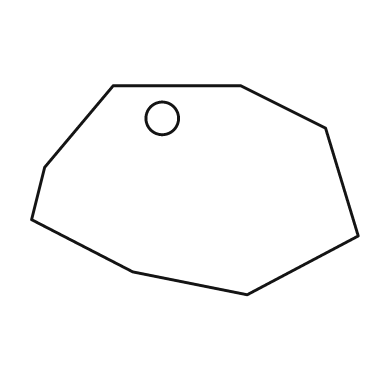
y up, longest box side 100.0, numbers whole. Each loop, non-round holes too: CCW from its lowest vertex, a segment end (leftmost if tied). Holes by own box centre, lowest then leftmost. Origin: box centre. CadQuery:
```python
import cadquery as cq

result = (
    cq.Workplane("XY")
    .moveTo(16.0, -32.0)
    .lineTo(50.0, -14.0)
    .lineTo(40.0, 19.0)
    .lineTo(14.0, 32.0)
    .lineTo(-25.0, 32.0)
    .lineTo(-46.0, 7.0)
    .lineTo(-50.0, -9.0)
    .lineTo(-19.0, -25.0)
    .close()
    .moveTo(-10.0, 22.0)
    .circle(5.0)
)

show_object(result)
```